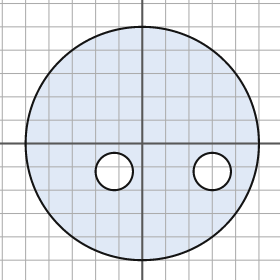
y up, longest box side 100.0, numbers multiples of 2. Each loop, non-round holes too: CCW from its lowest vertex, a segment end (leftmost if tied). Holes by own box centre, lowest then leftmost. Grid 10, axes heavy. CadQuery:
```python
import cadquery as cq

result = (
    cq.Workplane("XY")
    .moveTo(0.0, 0.0)
    .circle(50.0)
    .moveTo(-12.0, -12.0)
    .circle(8.0)
    .moveTo(30.0, -12.0)
    .circle(8.0)
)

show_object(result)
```